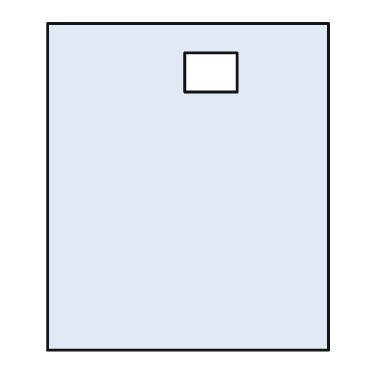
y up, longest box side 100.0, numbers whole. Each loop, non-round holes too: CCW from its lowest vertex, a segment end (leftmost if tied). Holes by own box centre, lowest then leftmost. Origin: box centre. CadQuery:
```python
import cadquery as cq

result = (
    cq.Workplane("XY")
    .moveTo(-43.0, -50.0)
    .lineTo(43.0, -50.0)
    .lineTo(43.0, 50.0)
    .lineTo(-43.0, 50.0)
    .close()
    .moveTo(-1.0, 29.0)
    .lineTo(15.0, 29.0)
    .lineTo(15.0, 41.0)
    .lineTo(-1.0, 41.0)
    .close()
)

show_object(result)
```